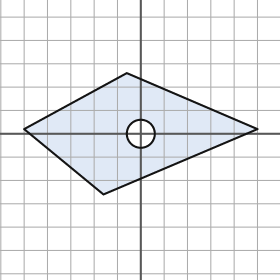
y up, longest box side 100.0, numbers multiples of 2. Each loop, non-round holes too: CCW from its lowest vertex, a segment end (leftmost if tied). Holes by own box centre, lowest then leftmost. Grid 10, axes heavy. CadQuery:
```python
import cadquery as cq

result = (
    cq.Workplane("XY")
    .moveTo(-16.0, -26.0)
    .lineTo(50.0, 2.0)
    .lineTo(-6.0, 26.0)
    .lineTo(-50.0, 2.0)
    .close()
    .moveTo(0.0, 0.0)
    .circle(6.0)
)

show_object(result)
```